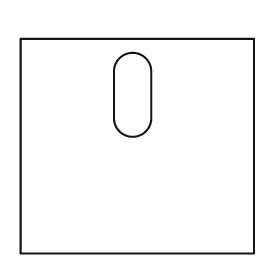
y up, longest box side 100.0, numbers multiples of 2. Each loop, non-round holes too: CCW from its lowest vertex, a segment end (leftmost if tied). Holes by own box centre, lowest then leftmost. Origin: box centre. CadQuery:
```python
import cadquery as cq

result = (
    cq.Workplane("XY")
    .moveTo(-50.0, -46.0)
    .lineTo(50.0, -46.0)
    .lineTo(50.0, 46.0)
    .lineTo(-50.0, 46.0)
    .close()
    .moveTo(-10.0, 12.0)
    .threePointArc((-2.0, 4.0), (6.0, 12.0))
    .lineTo(6.0, 32.0)
    .threePointArc((-2.0, 40.0), (-10.0, 32.0))
    .close()
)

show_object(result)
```